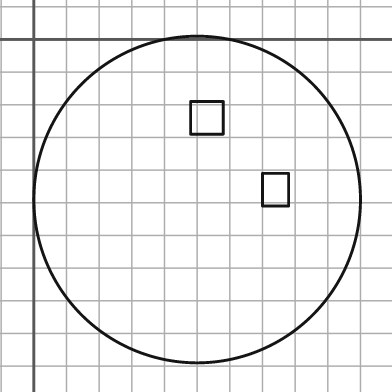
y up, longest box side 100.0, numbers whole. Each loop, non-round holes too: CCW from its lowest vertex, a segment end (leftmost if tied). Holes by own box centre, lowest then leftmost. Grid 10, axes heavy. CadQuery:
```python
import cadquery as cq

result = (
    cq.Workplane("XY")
    .moveTo(50.0, -49.0)
    .circle(50.0)
    .moveTo(70.0, -51.0)
    .lineTo(78.0, -51.0)
    .lineTo(78.0, -41.0)
    .lineTo(70.0, -41.0)
    .close()
    .moveTo(48.0, -29.0)
    .lineTo(58.0, -29.0)
    .lineTo(58.0, -19.0)
    .lineTo(48.0, -19.0)
    .close()
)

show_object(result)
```